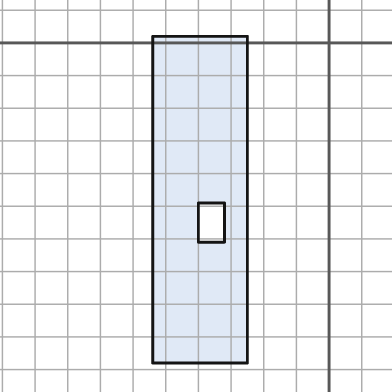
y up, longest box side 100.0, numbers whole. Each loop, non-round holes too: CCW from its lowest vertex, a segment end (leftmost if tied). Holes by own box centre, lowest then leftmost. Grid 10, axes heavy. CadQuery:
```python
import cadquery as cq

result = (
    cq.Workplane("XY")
    .moveTo(-54.0, -98.0)
    .lineTo(-25.0, -98.0)
    .lineTo(-25.0, 2.0)
    .lineTo(-54.0, 2.0)
    .close()
    .moveTo(-40.0, -61.0)
    .lineTo(-32.0, -61.0)
    .lineTo(-32.0, -49.0)
    .lineTo(-40.0, -49.0)
    .close()
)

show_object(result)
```